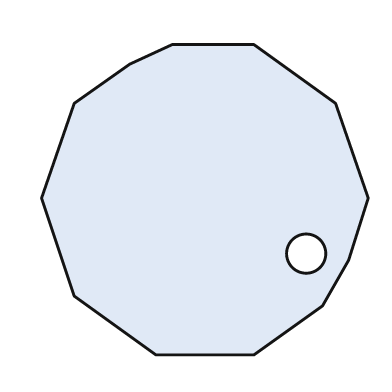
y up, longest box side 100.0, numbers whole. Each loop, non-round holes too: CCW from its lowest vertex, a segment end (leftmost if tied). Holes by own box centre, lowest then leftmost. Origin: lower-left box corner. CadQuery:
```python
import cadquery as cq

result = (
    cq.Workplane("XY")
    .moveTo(35.0, 0.0)
    .lineTo(65.0, 0.0)
    .lineTo(86.0, 15.0)
    .lineTo(94.0, 29.0)
    .lineTo(100.0, 48.0)
    .lineTo(90.0, 77.0)
    .lineTo(65.0, 95.0)
    .lineTo(40.0, 95.0)
    .lineTo(27.0, 89.0)
    .lineTo(10.0, 77.0)
    .lineTo(0.0, 48.0)
    .lineTo(10.0, 18.0)
    .close()
    .moveTo(81.0, 31.0)
    .circle(6.0)
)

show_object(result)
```